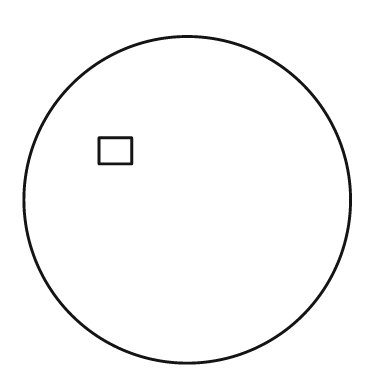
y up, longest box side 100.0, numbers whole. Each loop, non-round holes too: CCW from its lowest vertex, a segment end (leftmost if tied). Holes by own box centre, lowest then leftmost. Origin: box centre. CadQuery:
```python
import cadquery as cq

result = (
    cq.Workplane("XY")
    .moveTo(0.0, 0.0)
    .circle(50.0)
    .moveTo(-27.0, 11.0)
    .lineTo(-17.0, 11.0)
    .lineTo(-17.0, 19.0)
    .lineTo(-27.0, 19.0)
    .close()
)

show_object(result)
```